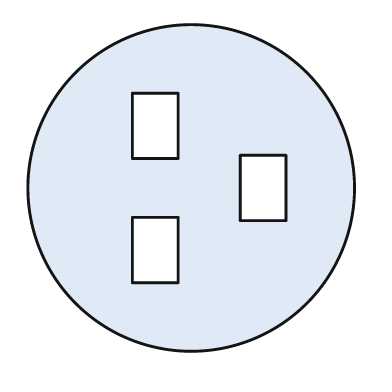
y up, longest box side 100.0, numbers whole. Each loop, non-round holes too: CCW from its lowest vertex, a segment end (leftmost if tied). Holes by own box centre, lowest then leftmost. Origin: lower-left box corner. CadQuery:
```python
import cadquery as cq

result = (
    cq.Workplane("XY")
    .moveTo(50.0, 50.0)
    .circle(50.0)
    .moveTo(32.0, 21.0)
    .lineTo(46.0, 21.0)
    .lineTo(46.0, 41.0)
    .lineTo(32.0, 41.0)
    .close()
    .moveTo(65.0, 40.0)
    .lineTo(79.0, 40.0)
    .lineTo(79.0, 60.0)
    .lineTo(65.0, 60.0)
    .close()
    .moveTo(32.0, 59.0)
    .lineTo(46.0, 59.0)
    .lineTo(46.0, 79.0)
    .lineTo(32.0, 79.0)
    .close()
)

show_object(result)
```